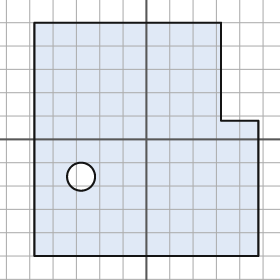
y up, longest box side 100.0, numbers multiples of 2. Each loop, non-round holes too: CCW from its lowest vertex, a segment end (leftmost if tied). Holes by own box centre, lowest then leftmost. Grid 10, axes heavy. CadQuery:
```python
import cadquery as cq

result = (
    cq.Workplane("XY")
    .moveTo(-48.0, -50.0)
    .lineTo(48.0, -50.0)
    .lineTo(48.0, 8.0)
    .lineTo(32.0, 8.0)
    .lineTo(32.0, 50.0)
    .lineTo(-48.0, 50.0)
    .close()
    .moveTo(-28.0, -16.0)
    .circle(6.0)
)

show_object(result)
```